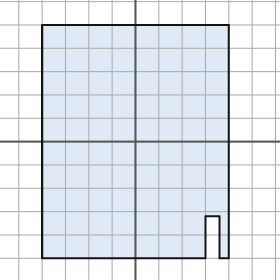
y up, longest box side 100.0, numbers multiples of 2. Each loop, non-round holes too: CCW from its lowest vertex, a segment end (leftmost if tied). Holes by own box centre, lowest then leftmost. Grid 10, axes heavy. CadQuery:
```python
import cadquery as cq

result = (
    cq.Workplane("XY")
    .moveTo(-40.0, -50.0)
    .lineTo(30.0, -50.0)
    .lineTo(30.0, -32.0)
    .lineTo(36.0, -32.0)
    .lineTo(36.0, -50.0)
    .lineTo(40.0, -50.0)
    .lineTo(40.0, 50.0)
    .lineTo(-40.0, 50.0)
    .close()
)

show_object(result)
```